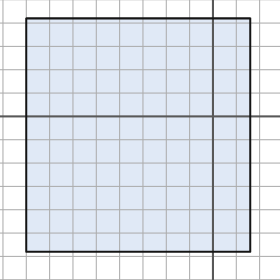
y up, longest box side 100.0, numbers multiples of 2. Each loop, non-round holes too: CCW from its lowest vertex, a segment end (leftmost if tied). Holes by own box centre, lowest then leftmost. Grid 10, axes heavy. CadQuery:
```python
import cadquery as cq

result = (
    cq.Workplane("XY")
    .moveTo(-80.0, -58.0)
    .lineTo(16.0, -58.0)
    .lineTo(16.0, 42.0)
    .lineTo(-80.0, 42.0)
    .close()
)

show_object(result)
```